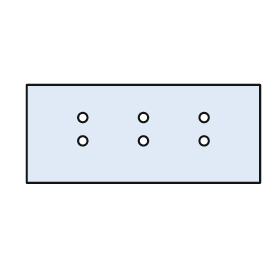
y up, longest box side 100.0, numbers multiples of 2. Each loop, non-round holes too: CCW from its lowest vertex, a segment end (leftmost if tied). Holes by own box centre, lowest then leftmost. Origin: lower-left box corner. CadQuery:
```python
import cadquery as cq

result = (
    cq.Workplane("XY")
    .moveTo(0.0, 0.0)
    .lineTo(100.0, 0.0)
    .lineTo(100.0, 42.0)
    .lineTo(0.0, 42.0)
    .close()
    .moveTo(24.0, 18.0)
    .circle(2.0)
    .moveTo(50.0, 18.0)
    .circle(2.0)
    .moveTo(76.0, 18.0)
    .circle(2.0)
    .moveTo(24.0, 28.0)
    .circle(2.0)
    .moveTo(50.0, 28.0)
    .circle(2.0)
    .moveTo(76.0, 28.0)
    .circle(2.0)
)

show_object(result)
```